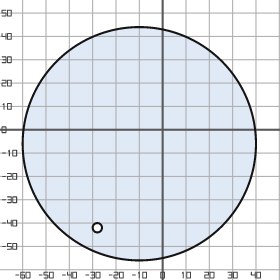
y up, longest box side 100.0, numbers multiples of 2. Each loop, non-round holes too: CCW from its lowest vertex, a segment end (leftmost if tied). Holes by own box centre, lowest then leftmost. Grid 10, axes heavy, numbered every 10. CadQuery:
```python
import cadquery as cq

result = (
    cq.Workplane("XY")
    .moveTo(-10.0, -6.0)
    .circle(50.0)
    .moveTo(-28.0, -42.0)
    .circle(2.0)
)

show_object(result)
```